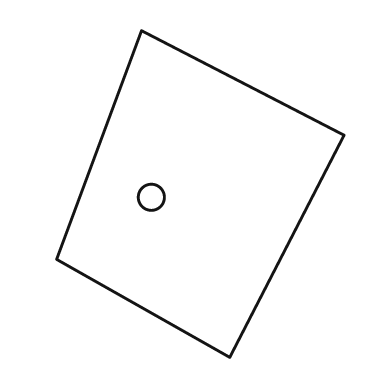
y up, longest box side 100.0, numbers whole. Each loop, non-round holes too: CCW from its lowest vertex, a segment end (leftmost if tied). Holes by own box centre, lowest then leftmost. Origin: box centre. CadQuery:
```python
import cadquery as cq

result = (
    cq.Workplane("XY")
    .moveTo(9.0, -50.0)
    .lineTo(44.0, 18.0)
    .lineTo(-18.0, 50.0)
    .lineTo(-44.0, -20.0)
    .close()
    .moveTo(-15.0, -1.0)
    .circle(4.0)
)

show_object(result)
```